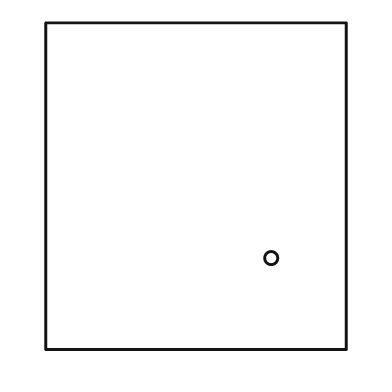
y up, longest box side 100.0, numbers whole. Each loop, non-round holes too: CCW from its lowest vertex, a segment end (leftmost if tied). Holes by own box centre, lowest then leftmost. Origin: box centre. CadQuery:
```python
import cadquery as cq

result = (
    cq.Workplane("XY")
    .moveTo(-46.0, -50.0)
    .lineTo(46.0, -50.0)
    .lineTo(46.0, 50.0)
    .lineTo(-46.0, 50.0)
    .close()
    .moveTo(23.0, -22.0)
    .circle(2.0)
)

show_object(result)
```